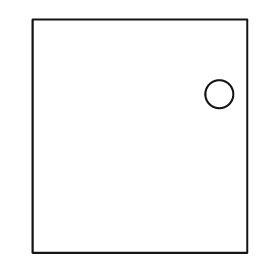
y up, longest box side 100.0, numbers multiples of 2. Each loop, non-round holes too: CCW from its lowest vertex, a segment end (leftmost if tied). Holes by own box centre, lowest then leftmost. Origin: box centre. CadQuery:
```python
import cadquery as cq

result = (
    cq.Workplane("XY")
    .moveTo(-46.0, -50.0)
    .lineTo(46.0, -50.0)
    .lineTo(46.0, 50.0)
    .lineTo(-46.0, 50.0)
    .close()
    .moveTo(34.0, 18.0)
    .circle(6.0)
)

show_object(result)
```